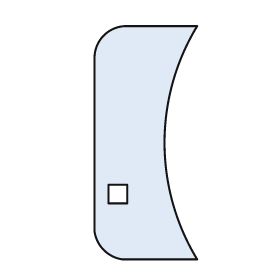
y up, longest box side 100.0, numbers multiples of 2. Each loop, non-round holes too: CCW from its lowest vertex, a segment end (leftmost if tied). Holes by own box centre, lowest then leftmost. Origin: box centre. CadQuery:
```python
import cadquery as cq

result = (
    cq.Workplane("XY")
    .moveTo(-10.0, -50.0)
    .lineTo(22.0, -50.0)
    .threePointArc((8.0, 0.0), (22.0, 50.0))
    .lineTo(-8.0, 50.0)
    .threePointArc((-18.0, 46.0), (-22.0, 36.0))
    .lineTo(-22.0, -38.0)
    .threePointArc((-18.0, -46.0), (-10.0, -50.0))
    .close()
    .moveTo(-16.0, -26.0)
    .lineTo(-8.0, -26.0)
    .lineTo(-8.0, -18.0)
    .lineTo(-16.0, -18.0)
    .close()
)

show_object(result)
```